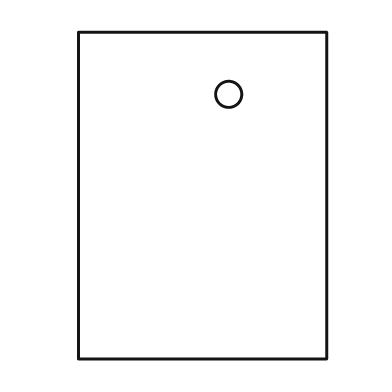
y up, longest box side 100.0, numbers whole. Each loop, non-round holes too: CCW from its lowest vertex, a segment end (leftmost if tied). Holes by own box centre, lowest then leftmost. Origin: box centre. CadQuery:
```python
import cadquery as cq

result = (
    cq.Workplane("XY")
    .moveTo(-38.0, -50.0)
    .lineTo(38.0, -50.0)
    .lineTo(38.0, 50.0)
    .lineTo(-38.0, 50.0)
    .close()
    .moveTo(8.0, 31.0)
    .circle(4.0)
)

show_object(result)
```